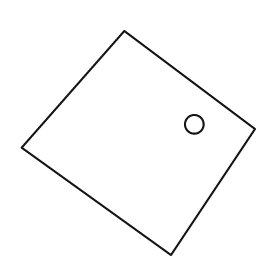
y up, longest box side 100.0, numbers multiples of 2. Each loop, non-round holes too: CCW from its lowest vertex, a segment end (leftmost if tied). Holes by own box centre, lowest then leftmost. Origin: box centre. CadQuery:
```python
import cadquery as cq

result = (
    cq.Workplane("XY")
    .moveTo(14.0, -48.0)
    .lineTo(50.0, 6.0)
    .lineTo(-6.0, 48.0)
    .lineTo(-50.0, -2.0)
    .close()
    .moveTo(24.0, 8.0)
    .circle(4.0)
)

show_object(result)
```